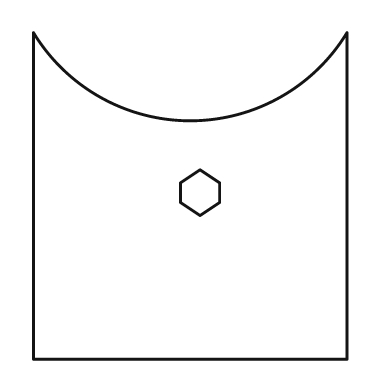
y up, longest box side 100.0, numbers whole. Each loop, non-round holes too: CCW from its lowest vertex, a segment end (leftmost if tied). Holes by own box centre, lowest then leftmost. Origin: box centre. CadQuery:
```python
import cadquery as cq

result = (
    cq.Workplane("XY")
    .moveTo(-48.0, -50.0)
    .lineTo(48.0, -50.0)
    .lineTo(48.0, 50.0)
    .threePointArc((0.0, 23.0), (-48.0, 50.0))
    .close()
    .moveTo(3.0, -6.0)
    .lineTo(9.0, -2.0)
    .lineTo(9.0, 4.0)
    .lineTo(3.0, 8.0)
    .lineTo(-3.0, 4.0)
    .lineTo(-3.0, -2.0)
    .close()
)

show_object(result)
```